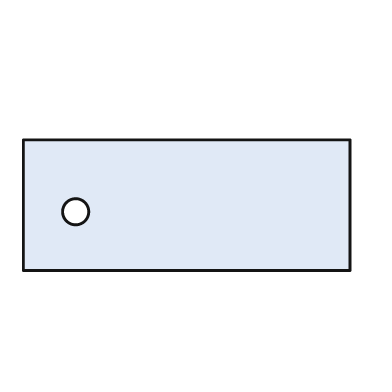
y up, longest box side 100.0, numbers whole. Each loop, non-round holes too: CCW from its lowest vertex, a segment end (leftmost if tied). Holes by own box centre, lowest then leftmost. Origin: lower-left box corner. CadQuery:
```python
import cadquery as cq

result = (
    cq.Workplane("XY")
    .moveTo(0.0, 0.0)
    .lineTo(100.0, 0.0)
    .lineTo(100.0, 40.0)
    .lineTo(0.0, 40.0)
    .close()
    .moveTo(16.0, 18.0)
    .circle(4.0)
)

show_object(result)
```